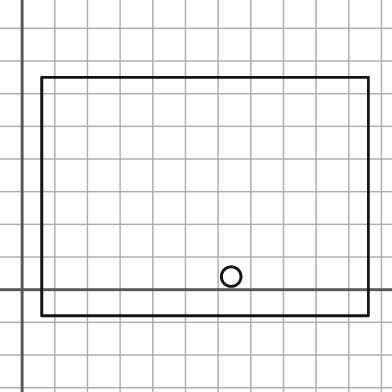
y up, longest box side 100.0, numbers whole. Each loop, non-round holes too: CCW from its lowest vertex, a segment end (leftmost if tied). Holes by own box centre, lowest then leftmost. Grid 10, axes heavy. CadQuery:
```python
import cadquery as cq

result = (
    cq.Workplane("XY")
    .moveTo(6.0, -8.0)
    .lineTo(106.0, -8.0)
    .lineTo(106.0, 65.0)
    .lineTo(6.0, 65.0)
    .close()
    .moveTo(64.0, 4.0)
    .circle(3.0)
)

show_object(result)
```